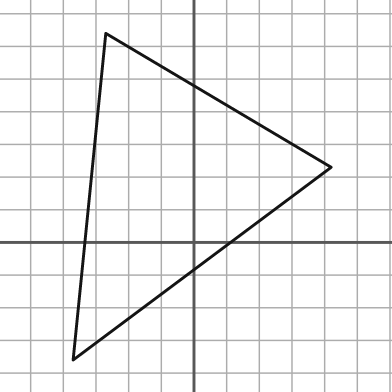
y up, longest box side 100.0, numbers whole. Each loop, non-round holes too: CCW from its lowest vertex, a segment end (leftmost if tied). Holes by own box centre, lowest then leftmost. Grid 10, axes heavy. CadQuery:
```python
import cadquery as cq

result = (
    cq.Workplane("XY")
    .moveTo(-37.0, -36.0)
    .lineTo(42.0, 23.0)
    .lineTo(-27.0, 64.0)
    .close()
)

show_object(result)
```